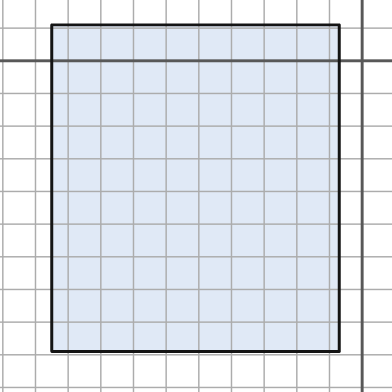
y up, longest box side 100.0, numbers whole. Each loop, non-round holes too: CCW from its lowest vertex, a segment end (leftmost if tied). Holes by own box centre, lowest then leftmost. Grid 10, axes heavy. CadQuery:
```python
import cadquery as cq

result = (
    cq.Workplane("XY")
    .moveTo(-95.0, -89.0)
    .lineTo(-7.0, -89.0)
    .lineTo(-7.0, 11.0)
    .lineTo(-95.0, 11.0)
    .close()
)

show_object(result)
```